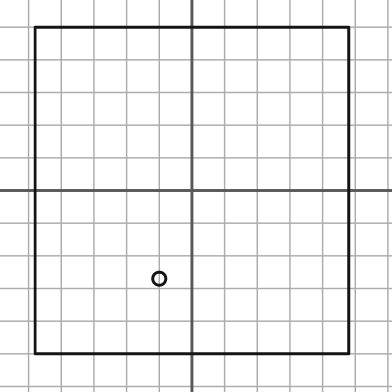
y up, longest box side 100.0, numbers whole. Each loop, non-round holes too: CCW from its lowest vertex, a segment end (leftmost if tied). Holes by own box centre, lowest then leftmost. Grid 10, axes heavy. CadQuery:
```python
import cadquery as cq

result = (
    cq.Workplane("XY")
    .moveTo(-48.0, -50.0)
    .lineTo(48.0, -50.0)
    .lineTo(48.0, 50.0)
    .lineTo(-48.0, 50.0)
    .close()
    .moveTo(-10.0, -27.0)
    .circle(2.0)
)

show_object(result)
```